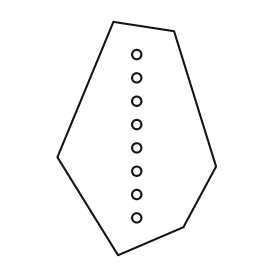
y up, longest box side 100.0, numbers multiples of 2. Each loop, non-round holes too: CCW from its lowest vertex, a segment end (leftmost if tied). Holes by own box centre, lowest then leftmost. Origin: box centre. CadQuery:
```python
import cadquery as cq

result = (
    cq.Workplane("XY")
    .moveTo(-8.0, -50.0)
    .lineTo(20.0, -38.0)
    .lineTo(34.0, -12.0)
    .lineTo(16.0, 46.0)
    .lineTo(-10.0, 50.0)
    .lineTo(-34.0, -8.0)
    .close()
    .moveTo(0.0, -34.0)
    .circle(2.0)
    .moveTo(0.0, -24.0)
    .circle(2.0)
    .moveTo(0.0, -14.0)
    .circle(2.0)
    .moveTo(0.0, -4.0)
    .circle(2.0)
    .moveTo(0.0, 6.0)
    .circle(2.0)
    .moveTo(0.0, 16.0)
    .circle(2.0)
    .moveTo(0.0, 26.0)
    .circle(2.0)
    .moveTo(0.0, 36.0)
    .circle(2.0)
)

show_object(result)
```